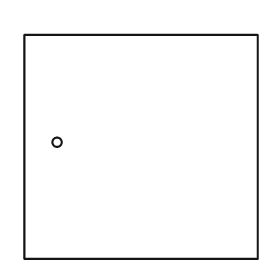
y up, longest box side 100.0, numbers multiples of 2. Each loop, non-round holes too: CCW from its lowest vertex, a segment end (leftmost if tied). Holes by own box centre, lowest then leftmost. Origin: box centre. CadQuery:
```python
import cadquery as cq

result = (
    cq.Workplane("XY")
    .moveTo(-50.0, -48.0)
    .lineTo(50.0, -48.0)
    .lineTo(50.0, 48.0)
    .lineTo(-50.0, 48.0)
    .close()
    .moveTo(-36.0, 2.0)
    .circle(2.0)
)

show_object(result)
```